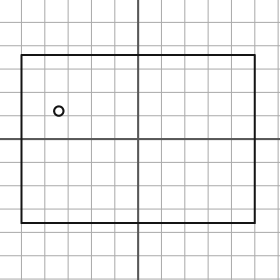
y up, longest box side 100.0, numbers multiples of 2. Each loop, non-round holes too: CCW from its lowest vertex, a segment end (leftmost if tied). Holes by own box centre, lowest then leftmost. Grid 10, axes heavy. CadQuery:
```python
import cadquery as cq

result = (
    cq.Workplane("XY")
    .moveTo(-50.0, -36.0)
    .lineTo(50.0, -36.0)
    .lineTo(50.0, 36.0)
    .lineTo(-50.0, 36.0)
    .close()
    .moveTo(-34.0, 12.0)
    .circle(2.0)
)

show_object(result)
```